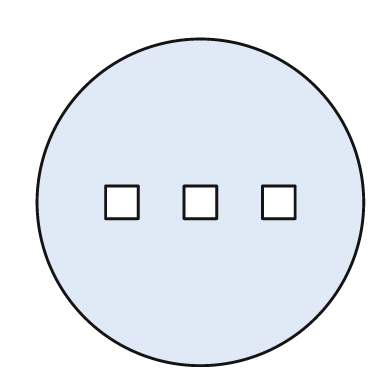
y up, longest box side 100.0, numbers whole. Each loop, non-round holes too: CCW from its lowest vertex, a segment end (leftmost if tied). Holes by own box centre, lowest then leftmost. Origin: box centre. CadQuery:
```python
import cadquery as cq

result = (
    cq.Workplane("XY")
    .moveTo(0.0, 0.0)
    .circle(50.0)
    .moveTo(-29.0, -5.0)
    .lineTo(-19.0, -5.0)
    .lineTo(-19.0, 5.0)
    .lineTo(-29.0, 5.0)
    .close()
    .moveTo(-5.0, -5.0)
    .lineTo(5.0, -5.0)
    .lineTo(5.0, 5.0)
    .lineTo(-5.0, 5.0)
    .close()
    .moveTo(19.0, -5.0)
    .lineTo(29.0, -5.0)
    .lineTo(29.0, 5.0)
    .lineTo(19.0, 5.0)
    .close()
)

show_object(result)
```